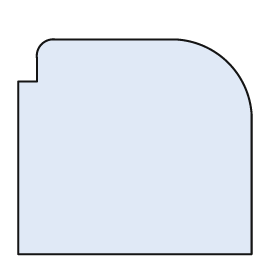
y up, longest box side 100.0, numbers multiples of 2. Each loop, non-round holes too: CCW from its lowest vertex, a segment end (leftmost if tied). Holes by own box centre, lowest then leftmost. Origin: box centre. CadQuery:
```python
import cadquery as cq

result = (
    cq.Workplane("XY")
    .moveTo(-50.0, -46.0)
    .lineTo(50.0, -46.0)
    .lineTo(50.0, 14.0)
    .threePointArc((40.0, 36.0), (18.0, 46.0))
    .lineTo(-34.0, 46.0)
    .threePointArc((-40.0, 44.0), (-42.0, 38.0))
    .lineTo(-42.0, 28.0)
    .lineTo(-50.0, 28.0)
    .close()
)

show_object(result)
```